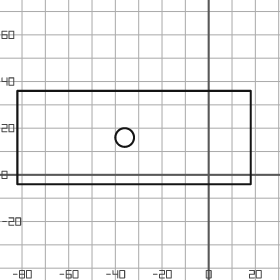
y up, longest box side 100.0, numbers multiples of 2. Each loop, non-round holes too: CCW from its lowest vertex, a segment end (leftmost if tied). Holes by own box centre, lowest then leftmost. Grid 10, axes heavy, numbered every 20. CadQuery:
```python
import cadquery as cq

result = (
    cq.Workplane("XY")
    .moveTo(-82.0, -4.0)
    .lineTo(18.0, -4.0)
    .lineTo(18.0, 36.0)
    .lineTo(-82.0, 36.0)
    .close()
    .moveTo(-36.0, 16.0)
    .circle(4.0)
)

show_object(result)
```